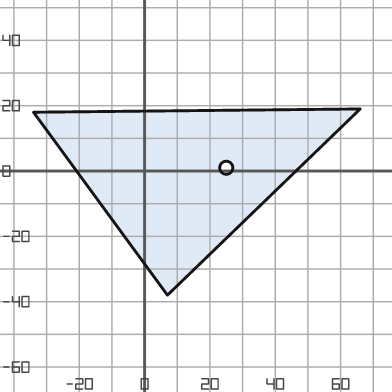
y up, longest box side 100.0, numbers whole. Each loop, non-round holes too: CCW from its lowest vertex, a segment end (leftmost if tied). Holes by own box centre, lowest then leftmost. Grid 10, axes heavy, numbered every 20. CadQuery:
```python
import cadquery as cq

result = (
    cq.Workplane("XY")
    .moveTo(7.0, -38.0)
    .lineTo(66.0, 19.0)
    .lineTo(-34.0, 18.0)
    .close()
    .moveTo(25.0, 1.0)
    .circle(2.0)
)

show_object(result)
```